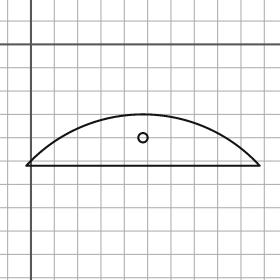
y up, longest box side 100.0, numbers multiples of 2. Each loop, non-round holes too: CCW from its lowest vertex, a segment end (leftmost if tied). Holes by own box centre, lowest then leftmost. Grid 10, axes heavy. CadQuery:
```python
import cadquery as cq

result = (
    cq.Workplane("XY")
    .moveTo(-2.0, -52.0)
    .lineTo(98.0, -52.0)
    .threePointArc((48.0, -30.0), (-2.0, -52.0))
    .close()
    .moveTo(48.0, -40.0)
    .circle(2.0)
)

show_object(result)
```